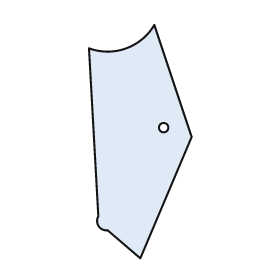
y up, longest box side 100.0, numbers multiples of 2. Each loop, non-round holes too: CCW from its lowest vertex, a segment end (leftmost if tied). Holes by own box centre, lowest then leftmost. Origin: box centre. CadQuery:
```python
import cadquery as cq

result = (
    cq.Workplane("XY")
    .moveTo(0.0, -50.0)
    .lineTo(22.0, 2.0)
    .lineTo(6.0, 50.0)
    .threePointArc((-6.0, 40.0), (-22.0, 40.0))
    .lineTo(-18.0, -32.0)
    .threePointArc((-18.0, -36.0), (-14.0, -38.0))
    .close()
    .moveTo(10.0, 6.0)
    .circle(2.0)
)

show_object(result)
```